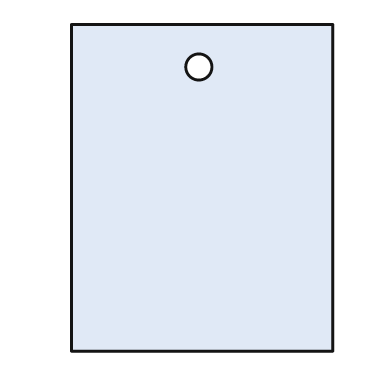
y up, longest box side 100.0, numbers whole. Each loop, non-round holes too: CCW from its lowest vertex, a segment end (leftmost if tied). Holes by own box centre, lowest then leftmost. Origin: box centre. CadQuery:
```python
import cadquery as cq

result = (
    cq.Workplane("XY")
    .moveTo(-40.0, -50.0)
    .lineTo(40.0, -50.0)
    .lineTo(40.0, 50.0)
    .lineTo(-40.0, 50.0)
    .close()
    .moveTo(-1.0, 37.0)
    .circle(4.0)
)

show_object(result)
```